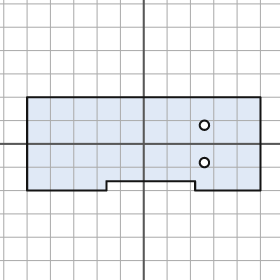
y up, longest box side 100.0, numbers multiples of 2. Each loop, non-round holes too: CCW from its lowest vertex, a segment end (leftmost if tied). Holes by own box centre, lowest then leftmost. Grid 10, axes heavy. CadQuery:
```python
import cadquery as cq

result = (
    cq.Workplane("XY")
    .moveTo(-50.0, -20.0)
    .lineTo(-16.0, -20.0)
    .lineTo(-16.0, -16.0)
    .lineTo(22.0, -16.0)
    .lineTo(22.0, -20.0)
    .lineTo(50.0, -20.0)
    .lineTo(50.0, 20.0)
    .lineTo(-50.0, 20.0)
    .close()
    .moveTo(26.0, -8.0)
    .circle(2.0)
    .moveTo(26.0, 8.0)
    .circle(2.0)
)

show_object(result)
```